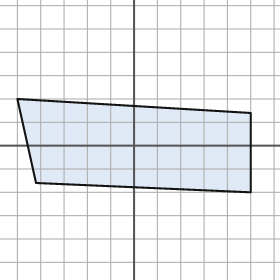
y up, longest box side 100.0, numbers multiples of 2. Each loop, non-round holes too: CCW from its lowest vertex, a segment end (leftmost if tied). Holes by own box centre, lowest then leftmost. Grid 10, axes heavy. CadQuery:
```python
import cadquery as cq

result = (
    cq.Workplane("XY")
    .moveTo(50.0, -20.0)
    .lineTo(50.0, 14.0)
    .lineTo(-50.0, 20.0)
    .lineTo(-42.0, -16.0)
    .close()
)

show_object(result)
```